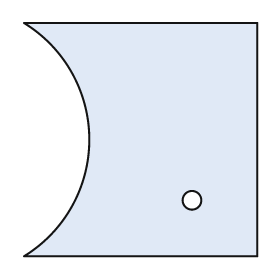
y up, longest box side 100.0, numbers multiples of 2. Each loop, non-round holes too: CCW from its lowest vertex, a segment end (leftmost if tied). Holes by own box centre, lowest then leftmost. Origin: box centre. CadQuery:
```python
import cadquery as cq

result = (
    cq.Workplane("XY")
    .moveTo(-50.0, -50.0)
    .lineTo(50.0, -50.0)
    .lineTo(50.0, 50.0)
    .lineTo(-50.0, 50.0)
    .threePointArc((-22.0, 0.0), (-50.0, -50.0))
    .close()
    .moveTo(22.0, -26.0)
    .circle(4.0)
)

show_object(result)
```